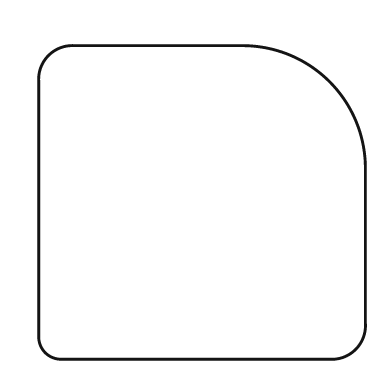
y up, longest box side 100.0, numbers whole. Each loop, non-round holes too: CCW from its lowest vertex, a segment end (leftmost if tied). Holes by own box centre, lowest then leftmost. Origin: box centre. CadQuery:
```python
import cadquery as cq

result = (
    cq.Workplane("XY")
    .moveTo(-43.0, -48.0)
    .lineTo(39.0, -48.0)
    .threePointArc((47.0, -45.0), (50.0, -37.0))
    .lineTo(50.0, 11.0)
    .threePointArc((39.0, 37.0), (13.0, 48.0))
    .lineTo(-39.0, 48.0)
    .threePointArc((-47.0, 45.0), (-50.0, 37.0))
    .lineTo(-50.0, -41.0)
    .threePointArc((-48.0, -46.0), (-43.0, -48.0))
    .close()
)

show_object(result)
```